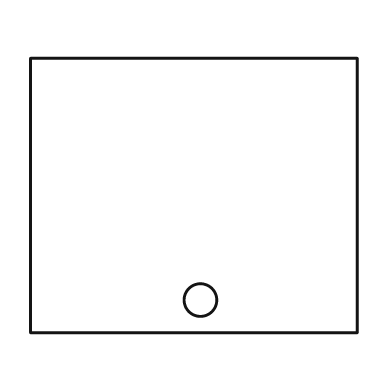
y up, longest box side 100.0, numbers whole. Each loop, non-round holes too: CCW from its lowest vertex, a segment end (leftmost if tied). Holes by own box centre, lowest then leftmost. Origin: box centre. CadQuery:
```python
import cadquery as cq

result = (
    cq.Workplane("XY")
    .moveTo(-50.0, -42.0)
    .lineTo(50.0, -42.0)
    .lineTo(50.0, 42.0)
    .lineTo(-50.0, 42.0)
    .close()
    .moveTo(2.0, -32.0)
    .circle(5.0)
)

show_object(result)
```